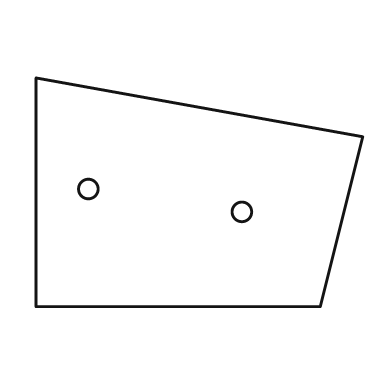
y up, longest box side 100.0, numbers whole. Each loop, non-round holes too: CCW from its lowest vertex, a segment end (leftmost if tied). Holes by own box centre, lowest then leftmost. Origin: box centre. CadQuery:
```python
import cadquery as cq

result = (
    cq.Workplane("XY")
    .moveTo(-50.0, -35.0)
    .lineTo(37.0, -35.0)
    .lineTo(50.0, 17.0)
    .lineTo(-50.0, 35.0)
    .close()
    .moveTo(13.0, -6.0)
    .circle(3.0)
    .moveTo(-34.0, 1.0)
    .circle(3.0)
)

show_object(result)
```